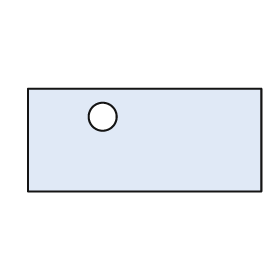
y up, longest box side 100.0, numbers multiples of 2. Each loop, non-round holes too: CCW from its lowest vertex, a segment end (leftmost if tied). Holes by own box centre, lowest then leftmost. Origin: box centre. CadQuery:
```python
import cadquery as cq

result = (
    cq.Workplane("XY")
    .moveTo(-50.0, -22.0)
    .lineTo(50.0, -22.0)
    .lineTo(50.0, 22.0)
    .lineTo(-50.0, 22.0)
    .close()
    .moveTo(-18.0, 10.0)
    .circle(6.0)
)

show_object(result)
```